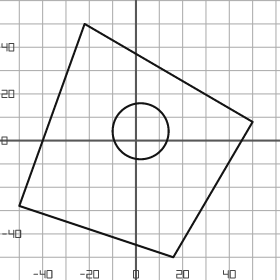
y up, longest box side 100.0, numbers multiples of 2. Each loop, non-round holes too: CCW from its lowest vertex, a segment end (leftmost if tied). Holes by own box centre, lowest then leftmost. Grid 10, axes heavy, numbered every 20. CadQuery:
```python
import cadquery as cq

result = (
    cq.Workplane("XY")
    .moveTo(16.0, -50.0)
    .lineTo(50.0, 8.0)
    .lineTo(-22.0, 50.0)
    .lineTo(-50.0, -28.0)
    .close()
    .moveTo(2.0, 4.0)
    .circle(12.0)
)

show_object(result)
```